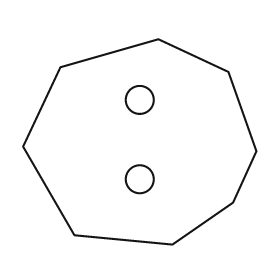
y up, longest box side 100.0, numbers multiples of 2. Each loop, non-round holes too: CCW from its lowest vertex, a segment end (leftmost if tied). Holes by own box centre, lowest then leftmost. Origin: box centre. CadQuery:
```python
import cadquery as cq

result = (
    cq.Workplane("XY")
    .moveTo(14.0, -44.0)
    .lineTo(40.0, -26.0)
    .lineTo(50.0, -4.0)
    .lineTo(38.0, 30.0)
    .lineTo(8.0, 44.0)
    .lineTo(-34.0, 32.0)
    .lineTo(-50.0, -2.0)
    .lineTo(-28.0, -40.0)
    .close()
    .moveTo(0.0, -16.0)
    .circle(6.0)
    .moveTo(0.0, 18.0)
    .circle(6.0)
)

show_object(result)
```